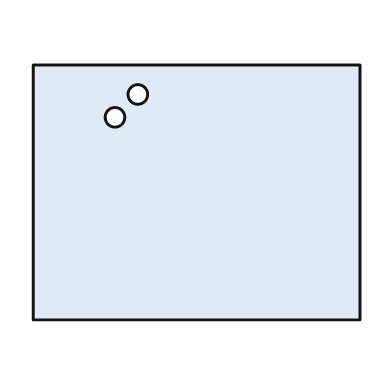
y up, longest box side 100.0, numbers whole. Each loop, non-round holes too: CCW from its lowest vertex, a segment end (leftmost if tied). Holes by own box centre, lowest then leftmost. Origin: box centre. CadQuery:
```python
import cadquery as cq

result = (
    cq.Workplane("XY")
    .moveTo(-50.0, -39.0)
    .lineTo(50.0, -39.0)
    .lineTo(50.0, 39.0)
    .lineTo(-50.0, 39.0)
    .close()
    .moveTo(-25.0, 23.0)
    .circle(3.0)
    .moveTo(-18.0, 30.0)
    .circle(3.0)
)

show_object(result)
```